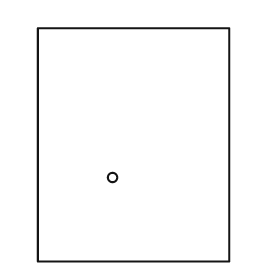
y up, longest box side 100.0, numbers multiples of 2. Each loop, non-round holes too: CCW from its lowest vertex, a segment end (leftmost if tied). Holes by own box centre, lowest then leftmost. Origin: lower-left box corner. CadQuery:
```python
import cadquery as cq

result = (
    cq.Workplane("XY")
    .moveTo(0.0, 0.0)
    .lineTo(82.0, 0.0)
    .lineTo(82.0, 100.0)
    .lineTo(0.0, 100.0)
    .close()
    .moveTo(32.0, 36.0)
    .circle(2.0)
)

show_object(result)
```